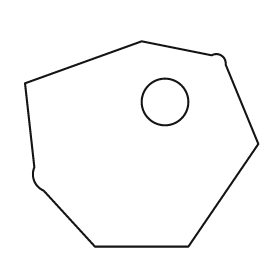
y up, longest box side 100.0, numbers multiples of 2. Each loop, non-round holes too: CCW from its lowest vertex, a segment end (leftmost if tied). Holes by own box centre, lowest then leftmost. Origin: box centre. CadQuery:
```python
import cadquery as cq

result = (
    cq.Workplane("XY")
    .moveTo(-20.0, -44.0)
    .lineTo(20.0, -44.0)
    .lineTo(50.0, 0.0)
    .lineTo(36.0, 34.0)
    .threePointArc((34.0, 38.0), (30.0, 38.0))
    .lineTo(0.0, 44.0)
    .lineTo(-50.0, 26.0)
    .lineTo(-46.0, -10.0)
    .threePointArc((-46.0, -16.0), (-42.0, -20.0))
    .close()
    .moveTo(10.0, 18.0)
    .circle(10.0)
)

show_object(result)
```